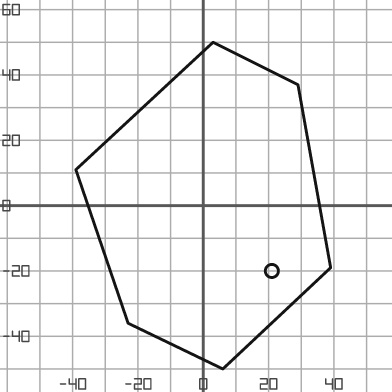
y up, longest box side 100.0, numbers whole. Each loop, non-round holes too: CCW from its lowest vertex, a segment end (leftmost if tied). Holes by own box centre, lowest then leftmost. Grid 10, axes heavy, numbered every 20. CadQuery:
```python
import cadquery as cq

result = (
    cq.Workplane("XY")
    .moveTo(6.0, -50.0)
    .lineTo(39.0, -19.0)
    .lineTo(29.0, 37.0)
    .lineTo(3.0, 50.0)
    .lineTo(-39.0, 11.0)
    .lineTo(-23.0, -36.0)
    .close()
    .moveTo(21.0, -20.0)
    .circle(2.0)
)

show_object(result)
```